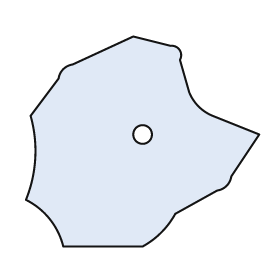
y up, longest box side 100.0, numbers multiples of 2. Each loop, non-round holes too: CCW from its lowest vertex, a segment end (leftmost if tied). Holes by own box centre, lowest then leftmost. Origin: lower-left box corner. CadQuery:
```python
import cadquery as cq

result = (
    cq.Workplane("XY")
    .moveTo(16.0, 0.0)
    .lineTo(50.0, 0.0)
    .threePointArc((58.0, 6.0), (64.0, 14.0))
    .lineTo(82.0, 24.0)
    .threePointArc((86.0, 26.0), (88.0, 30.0))
    .lineTo(100.0, 48.0)
    .lineTo(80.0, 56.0)
    .threePointArc((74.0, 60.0), (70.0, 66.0))
    .lineTo(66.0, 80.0)
    .threePointArc((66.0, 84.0), (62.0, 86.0))
    .lineTo(46.0, 90.0)
    .lineTo(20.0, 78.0)
    .threePointArc((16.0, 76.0), (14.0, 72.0))
    .lineTo(2.0, 56.0)
    .threePointArc((4.0, 38.0), (0.0, 20.0))
    .threePointArc((10.0, 12.0), (16.0, 0.0))
    .close()
    .moveTo(50.0, 48.0)
    .circle(4.0)
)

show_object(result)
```